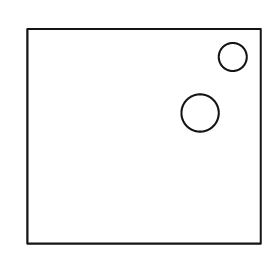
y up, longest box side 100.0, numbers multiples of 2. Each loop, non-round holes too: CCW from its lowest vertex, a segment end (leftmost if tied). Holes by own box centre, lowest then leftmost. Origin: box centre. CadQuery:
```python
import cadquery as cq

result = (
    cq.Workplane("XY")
    .moveTo(-50.0, -46.0)
    .lineTo(50.0, -46.0)
    .lineTo(50.0, 46.0)
    .lineTo(-50.0, 46.0)
    .close()
    .moveTo(24.0, 10.0)
    .circle(8.0)
    .moveTo(38.0, 34.0)
    .circle(6.0)
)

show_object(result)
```